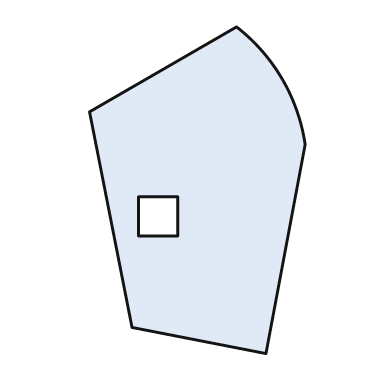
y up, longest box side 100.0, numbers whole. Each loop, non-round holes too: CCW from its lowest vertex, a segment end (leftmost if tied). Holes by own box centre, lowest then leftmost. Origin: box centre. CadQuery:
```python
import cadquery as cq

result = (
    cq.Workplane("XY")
    .moveTo(21.0, -50.0)
    .lineTo(33.0, 14.0)
    .threePointArc((26.0, 34.0), (12.0, 50.0))
    .lineTo(-33.0, 24.0)
    .lineTo(-20.0, -42.0)
    .close()
    .moveTo(-18.0, -14.0)
    .lineTo(-6.0, -14.0)
    .lineTo(-6.0, -2.0)
    .lineTo(-18.0, -2.0)
    .close()
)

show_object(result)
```